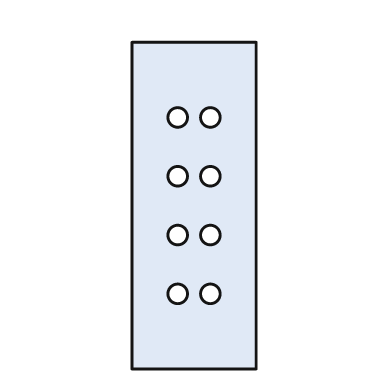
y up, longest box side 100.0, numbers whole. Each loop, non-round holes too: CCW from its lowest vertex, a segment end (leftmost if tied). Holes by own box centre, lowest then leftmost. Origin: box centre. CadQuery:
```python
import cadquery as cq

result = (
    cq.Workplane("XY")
    .moveTo(-19.0, -50.0)
    .lineTo(19.0, -50.0)
    .lineTo(19.0, 50.0)
    .lineTo(-19.0, 50.0)
    .close()
    .moveTo(-5.0, -27.0)
    .circle(3.0)
    .moveTo(5.0, -27.0)
    .circle(3.0)
    .moveTo(-5.0, -9.0)
    .circle(3.0)
    .moveTo(5.0, -9.0)
    .circle(3.0)
    .moveTo(-5.0, 9.0)
    .circle(3.0)
    .moveTo(5.0, 9.0)
    .circle(3.0)
    .moveTo(-5.0, 27.0)
    .circle(3.0)
    .moveTo(5.0, 27.0)
    .circle(3.0)
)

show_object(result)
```